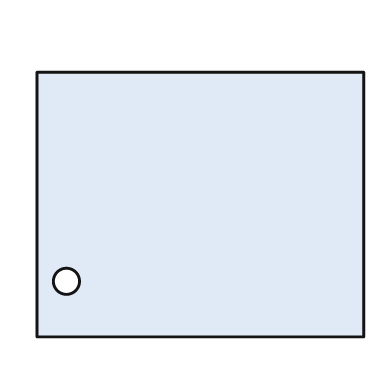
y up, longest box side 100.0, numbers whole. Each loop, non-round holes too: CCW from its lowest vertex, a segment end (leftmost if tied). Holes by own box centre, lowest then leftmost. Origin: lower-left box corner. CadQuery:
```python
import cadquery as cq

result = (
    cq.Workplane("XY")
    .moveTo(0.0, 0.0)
    .lineTo(100.0, 0.0)
    .lineTo(100.0, 81.0)
    .lineTo(0.0, 81.0)
    .close()
    .moveTo(9.0, 17.0)
    .circle(4.0)
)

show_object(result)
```